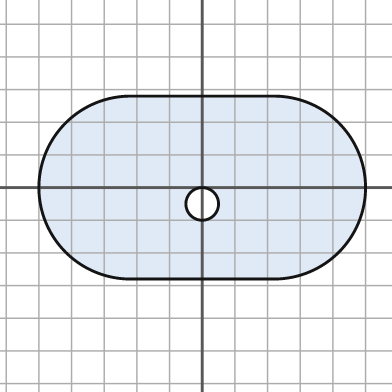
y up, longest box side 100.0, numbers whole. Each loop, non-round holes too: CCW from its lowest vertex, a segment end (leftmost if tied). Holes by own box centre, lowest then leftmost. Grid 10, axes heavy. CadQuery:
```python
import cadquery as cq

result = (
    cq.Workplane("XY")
    .moveTo(-22.0, -28.0)
    .lineTo(22.0, -28.0)
    .threePointArc((50.0, 0.0), (22.0, 28.0))
    .lineTo(-22.0, 28.0)
    .threePointArc((-50.0, 0.0), (-22.0, -28.0))
    .close()
    .moveTo(0.0, -5.0)
    .circle(5.0)
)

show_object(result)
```